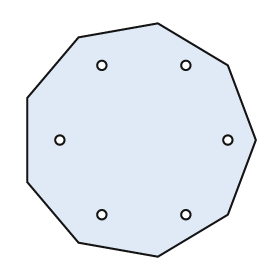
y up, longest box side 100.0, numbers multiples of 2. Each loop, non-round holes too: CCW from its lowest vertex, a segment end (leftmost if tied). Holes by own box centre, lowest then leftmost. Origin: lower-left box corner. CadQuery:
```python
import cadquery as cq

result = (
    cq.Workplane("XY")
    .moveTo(56.0, 0.0)
    .lineTo(86.0, 18.0)
    .lineTo(98.0, 50.0)
    .lineTo(86.0, 82.0)
    .lineTo(56.0, 100.0)
    .lineTo(22.0, 94.0)
    .lineTo(0.0, 68.0)
    .lineTo(0.0, 32.0)
    .lineTo(22.0, 6.0)
    .close()
    .moveTo(32.0, 18.0)
    .circle(2.0)
    .moveTo(68.0, 18.0)
    .circle(2.0)
    .moveTo(14.0, 50.0)
    .circle(2.0)
    .moveTo(86.0, 50.0)
    .circle(2.0)
    .moveTo(32.0, 82.0)
    .circle(2.0)
    .moveTo(68.0, 82.0)
    .circle(2.0)
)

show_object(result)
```